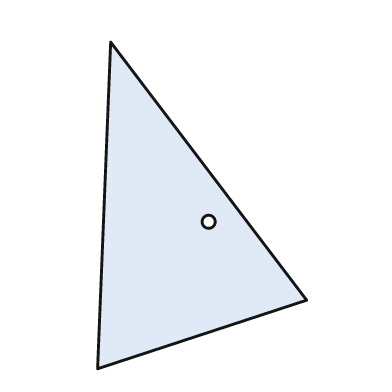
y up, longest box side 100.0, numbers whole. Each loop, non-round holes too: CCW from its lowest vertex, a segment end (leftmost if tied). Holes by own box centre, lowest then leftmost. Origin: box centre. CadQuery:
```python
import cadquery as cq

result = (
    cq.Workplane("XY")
    .moveTo(-32.0, -50.0)
    .lineTo(32.0, -29.0)
    .lineTo(-28.0, 50.0)
    .close()
    .moveTo(2.0, -5.0)
    .circle(2.0)
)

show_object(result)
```